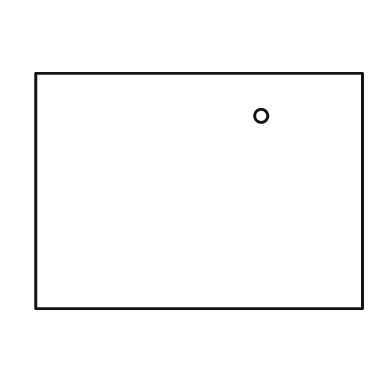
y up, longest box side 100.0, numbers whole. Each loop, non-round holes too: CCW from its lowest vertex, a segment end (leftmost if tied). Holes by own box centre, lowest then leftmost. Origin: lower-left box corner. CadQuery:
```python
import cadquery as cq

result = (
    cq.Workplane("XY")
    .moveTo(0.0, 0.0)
    .lineTo(100.0, 0.0)
    .lineTo(100.0, 72.0)
    .lineTo(0.0, 72.0)
    .close()
    .moveTo(69.0, 59.0)
    .circle(2.0)
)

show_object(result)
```